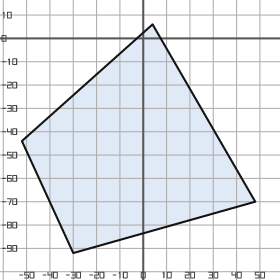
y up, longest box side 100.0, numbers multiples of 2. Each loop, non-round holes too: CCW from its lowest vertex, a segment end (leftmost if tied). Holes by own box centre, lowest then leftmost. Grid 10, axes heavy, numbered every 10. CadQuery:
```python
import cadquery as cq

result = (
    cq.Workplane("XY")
    .moveTo(-30.0, -92.0)
    .lineTo(48.0, -70.0)
    .lineTo(4.0, 6.0)
    .lineTo(-52.0, -44.0)
    .close()
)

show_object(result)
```